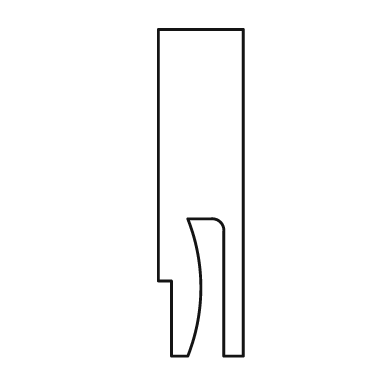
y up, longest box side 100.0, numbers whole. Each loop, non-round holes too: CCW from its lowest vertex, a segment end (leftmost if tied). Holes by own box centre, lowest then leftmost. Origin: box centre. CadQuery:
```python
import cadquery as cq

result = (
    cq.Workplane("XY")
    .moveTo(-9.0, -50.0)
    .lineTo(-4.0, -50.0)
    .threePointArc((0.0, -29.0), (-4.0, -8.0))
    .lineTo(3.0, -8.0)
    .threePointArc((6.0, -9.0), (7.0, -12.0))
    .lineTo(7.0, -50.0)
    .lineTo(13.0, -50.0)
    .lineTo(13.0, 50.0)
    .lineTo(-13.0, 50.0)
    .lineTo(-13.0, -27.0)
    .lineTo(-9.0, -27.0)
    .close()
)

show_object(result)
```